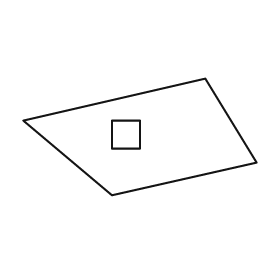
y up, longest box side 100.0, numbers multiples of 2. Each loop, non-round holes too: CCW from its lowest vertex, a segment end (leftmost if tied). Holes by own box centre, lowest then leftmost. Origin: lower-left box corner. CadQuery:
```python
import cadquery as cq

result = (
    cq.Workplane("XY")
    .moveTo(38.0, 0.0)
    .lineTo(100.0, 14.0)
    .lineTo(78.0, 50.0)
    .lineTo(0.0, 32.0)
    .close()
    .moveTo(38.0, 20.0)
    .lineTo(50.0, 20.0)
    .lineTo(50.0, 32.0)
    .lineTo(38.0, 32.0)
    .close()
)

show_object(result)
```